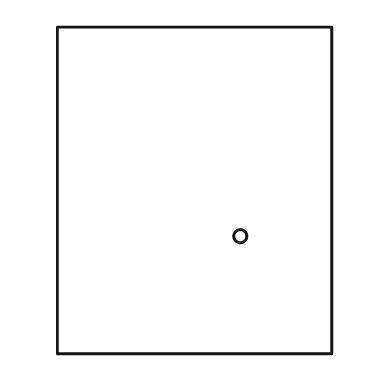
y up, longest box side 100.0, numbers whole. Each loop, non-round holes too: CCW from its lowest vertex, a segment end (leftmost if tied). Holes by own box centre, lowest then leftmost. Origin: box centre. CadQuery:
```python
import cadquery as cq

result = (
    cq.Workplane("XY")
    .moveTo(-42.0, -50.0)
    .lineTo(42.0, -50.0)
    .lineTo(42.0, 50.0)
    .lineTo(-42.0, 50.0)
    .close()
    .moveTo(14.0, -14.0)
    .circle(2.0)
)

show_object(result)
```